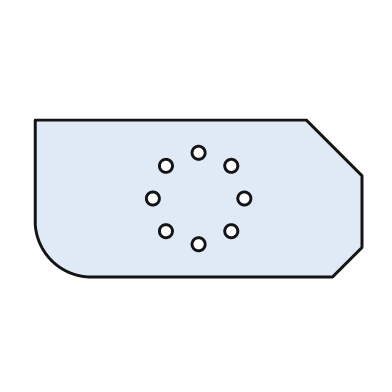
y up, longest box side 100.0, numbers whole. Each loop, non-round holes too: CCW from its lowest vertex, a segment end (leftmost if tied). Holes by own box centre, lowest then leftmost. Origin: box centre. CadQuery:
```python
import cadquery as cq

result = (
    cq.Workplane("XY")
    .moveTo(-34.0, -24.0)
    .lineTo(41.0, -24.0)
    .lineTo(50.0, -15.0)
    .lineTo(50.0, 7.0)
    .lineTo(33.0, 24.0)
    .lineTo(-50.0, 24.0)
    .lineTo(-50.0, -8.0)
    .threePointArc((-45.0, -19.0), (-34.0, -24.0))
    .close()
    .moveTo(0.0, -14.0)
    .circle(2.0)
    .moveTo(-10.0, -10.0)
    .circle(2.0)
    .moveTo(10.0, -10.0)
    .circle(2.0)
    .moveTo(-14.0, 0.0)
    .circle(2.0)
    .moveTo(14.0, 0.0)
    .circle(2.0)
    .moveTo(-10.0, 10.0)
    .circle(2.0)
    .moveTo(10.0, 10.0)
    .circle(2.0)
    .moveTo(0.0, 14.0)
    .circle(2.0)
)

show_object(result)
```